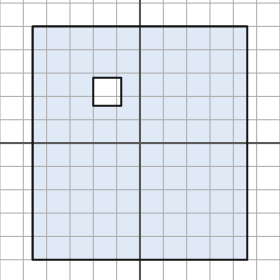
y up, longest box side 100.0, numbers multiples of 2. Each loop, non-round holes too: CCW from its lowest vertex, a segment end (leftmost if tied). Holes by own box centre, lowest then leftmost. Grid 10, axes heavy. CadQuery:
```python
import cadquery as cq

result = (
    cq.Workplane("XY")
    .moveTo(-46.0, -50.0)
    .lineTo(46.0, -50.0)
    .lineTo(46.0, 50.0)
    .lineTo(-46.0, 50.0)
    .close()
    .moveTo(-20.0, 16.0)
    .lineTo(-8.0, 16.0)
    .lineTo(-8.0, 28.0)
    .lineTo(-20.0, 28.0)
    .close()
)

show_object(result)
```